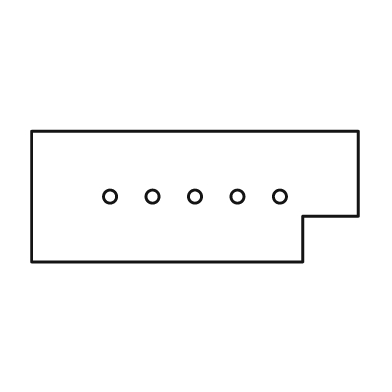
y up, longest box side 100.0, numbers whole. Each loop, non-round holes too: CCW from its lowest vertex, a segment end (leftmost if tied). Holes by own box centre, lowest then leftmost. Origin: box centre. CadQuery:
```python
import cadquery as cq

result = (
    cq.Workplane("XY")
    .moveTo(-50.0, -20.0)
    .lineTo(33.0, -20.0)
    .lineTo(33.0, -6.0)
    .lineTo(50.0, -6.0)
    .lineTo(50.0, 20.0)
    .lineTo(-50.0, 20.0)
    .close()
    .moveTo(-26.0, 0.0)
    .circle(2.0)
    .moveTo(-13.0, 0.0)
    .circle(2.0)
    .moveTo(0.0, 0.0)
    .circle(2.0)
    .moveTo(13.0, 0.0)
    .circle(2.0)
    .moveTo(26.0, 0.0)
    .circle(2.0)
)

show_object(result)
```